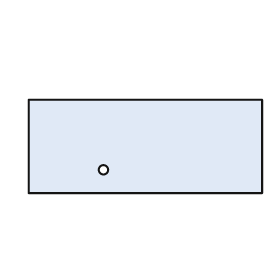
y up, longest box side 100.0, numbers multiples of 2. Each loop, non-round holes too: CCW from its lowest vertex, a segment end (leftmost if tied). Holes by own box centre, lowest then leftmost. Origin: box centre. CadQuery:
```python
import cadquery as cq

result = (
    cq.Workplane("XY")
    .moveTo(-50.0, -20.0)
    .lineTo(50.0, -20.0)
    .lineTo(50.0, 20.0)
    .lineTo(-50.0, 20.0)
    .close()
    .moveTo(-18.0, -10.0)
    .circle(2.0)
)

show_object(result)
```